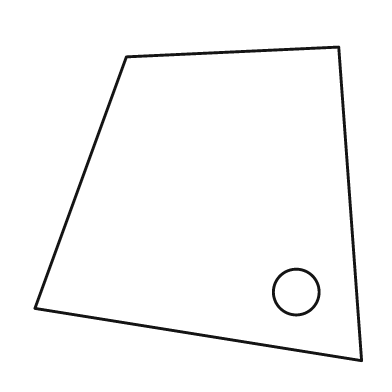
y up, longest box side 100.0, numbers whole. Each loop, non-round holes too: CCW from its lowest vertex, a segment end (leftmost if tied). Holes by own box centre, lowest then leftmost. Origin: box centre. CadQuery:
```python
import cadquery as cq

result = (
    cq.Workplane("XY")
    .moveTo(50.0, -48.0)
    .lineTo(43.0, 48.0)
    .lineTo(-22.0, 45.0)
    .lineTo(-50.0, -32.0)
    .close()
    .moveTo(30.0, -27.0)
    .circle(7.0)
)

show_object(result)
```